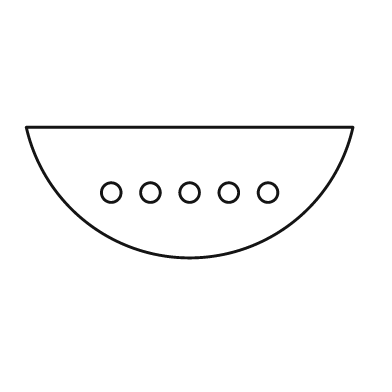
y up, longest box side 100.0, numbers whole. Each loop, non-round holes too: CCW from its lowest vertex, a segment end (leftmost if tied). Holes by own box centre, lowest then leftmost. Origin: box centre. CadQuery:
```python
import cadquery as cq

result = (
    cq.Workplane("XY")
    .moveTo(-50.0, 20.0)
    .threePointArc((0.0, -20.0), (50.0, 20.0))
    .close()
    .moveTo(-24.0, 0.0)
    .circle(3.0)
    .moveTo(-12.0, 0.0)
    .circle(3.0)
    .moveTo(0.0, 0.0)
    .circle(3.0)
    .moveTo(12.0, 0.0)
    .circle(3.0)
    .moveTo(24.0, 0.0)
    .circle(3.0)
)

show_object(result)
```